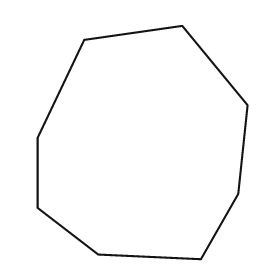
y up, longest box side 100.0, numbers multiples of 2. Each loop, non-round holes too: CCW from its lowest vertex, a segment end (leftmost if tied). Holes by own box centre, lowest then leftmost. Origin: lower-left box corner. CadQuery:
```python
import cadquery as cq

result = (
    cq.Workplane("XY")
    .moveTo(70.0, 0.0)
    .lineTo(86.0, 28.0)
    .lineTo(90.0, 66.0)
    .lineTo(62.0, 100.0)
    .lineTo(20.0, 94.0)
    .lineTo(0.0, 52.0)
    .lineTo(0.0, 22.0)
    .lineTo(26.0, 2.0)
    .close()
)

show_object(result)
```